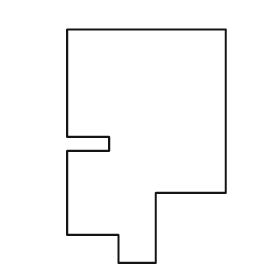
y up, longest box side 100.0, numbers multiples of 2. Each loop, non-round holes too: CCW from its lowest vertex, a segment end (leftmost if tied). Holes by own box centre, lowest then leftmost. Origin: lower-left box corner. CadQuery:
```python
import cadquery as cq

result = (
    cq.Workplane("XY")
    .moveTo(22.0, 0.0)
    .lineTo(38.0, 0.0)
    .lineTo(38.0, 30.0)
    .lineTo(68.0, 30.0)
    .lineTo(68.0, 100.0)
    .lineTo(0.0, 100.0)
    .lineTo(0.0, 54.0)
    .lineTo(18.0, 54.0)
    .lineTo(18.0, 48.0)
    .lineTo(0.0, 48.0)
    .lineTo(0.0, 12.0)
    .lineTo(22.0, 12.0)
    .close()
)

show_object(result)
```